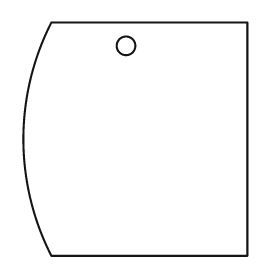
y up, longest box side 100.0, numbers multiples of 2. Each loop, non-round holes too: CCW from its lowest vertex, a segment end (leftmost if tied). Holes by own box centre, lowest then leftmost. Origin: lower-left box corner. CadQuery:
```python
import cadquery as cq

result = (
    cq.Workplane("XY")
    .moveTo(12.0, 0.0)
    .lineTo(96.0, 0.0)
    .lineTo(96.0, 100.0)
    .lineTo(12.0, 100.0)
    .threePointArc((0.0, 50.0), (12.0, 0.0))
    .close()
    .moveTo(44.0, 90.0)
    .circle(4.0)
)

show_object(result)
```